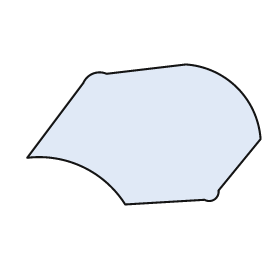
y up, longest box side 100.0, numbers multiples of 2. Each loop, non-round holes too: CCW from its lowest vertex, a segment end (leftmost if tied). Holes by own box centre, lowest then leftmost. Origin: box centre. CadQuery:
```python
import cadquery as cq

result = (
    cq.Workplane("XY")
    .moveTo(-8.0, -30.0)
    .lineTo(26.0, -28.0)
    .threePointArc((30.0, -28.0), (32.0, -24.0))
    .lineTo(50.0, -2.0)
    .threePointArc((40.0, 20.0), (18.0, 30.0))
    .lineTo(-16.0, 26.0)
    .threePointArc((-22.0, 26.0), (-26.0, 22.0))
    .lineTo(-50.0, -10.0)
    .threePointArc((-26.0, -14.0), (-8.0, -30.0))
    .close()
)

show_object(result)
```